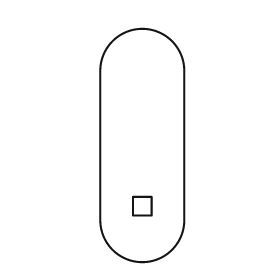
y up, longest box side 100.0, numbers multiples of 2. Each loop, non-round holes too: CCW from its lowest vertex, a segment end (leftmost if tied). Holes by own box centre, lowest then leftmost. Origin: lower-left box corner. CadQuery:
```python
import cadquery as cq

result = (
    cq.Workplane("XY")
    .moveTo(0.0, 18.0)
    .threePointArc((18.0, 0.0), (36.0, 18.0))
    .lineTo(36.0, 82.0)
    .threePointArc((18.0, 100.0), (0.0, 82.0))
    .close()
    .moveTo(14.0, 20.0)
    .lineTo(22.0, 20.0)
    .lineTo(22.0, 28.0)
    .lineTo(14.0, 28.0)
    .close()
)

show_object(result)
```